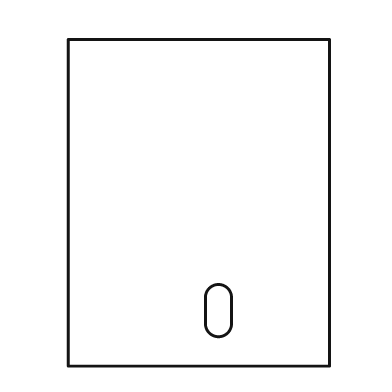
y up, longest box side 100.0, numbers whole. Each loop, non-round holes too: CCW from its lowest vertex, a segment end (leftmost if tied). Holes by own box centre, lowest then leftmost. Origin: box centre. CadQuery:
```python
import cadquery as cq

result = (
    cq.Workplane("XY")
    .moveTo(-40.0, -50.0)
    .lineTo(40.0, -50.0)
    .lineTo(40.0, 50.0)
    .lineTo(-40.0, 50.0)
    .close()
    .moveTo(2.0, -37.0)
    .threePointArc((6.0, -41.0), (10.0, -37.0))
    .lineTo(10.0, -29.0)
    .threePointArc((6.0, -25.0), (2.0, -29.0))
    .close()
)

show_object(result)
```